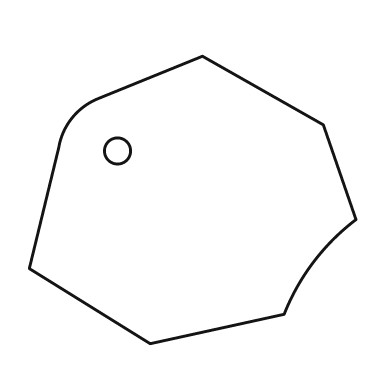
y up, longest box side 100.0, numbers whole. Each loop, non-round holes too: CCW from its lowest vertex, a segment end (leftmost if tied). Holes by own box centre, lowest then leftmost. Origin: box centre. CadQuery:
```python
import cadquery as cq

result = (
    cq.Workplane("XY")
    .moveTo(-13.0, -44.0)
    .lineTo(28.0, -35.0)
    .threePointArc((37.0, -19.0), (50.0, -6.0))
    .lineTo(40.0, 23.0)
    .lineTo(3.0, 44.0)
    .lineTo(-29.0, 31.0)
    .threePointArc((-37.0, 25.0), (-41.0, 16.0))
    .lineTo(-50.0, -21.0)
    .close()
    .moveTo(-23.0, 15.0)
    .circle(4.0)
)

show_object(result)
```